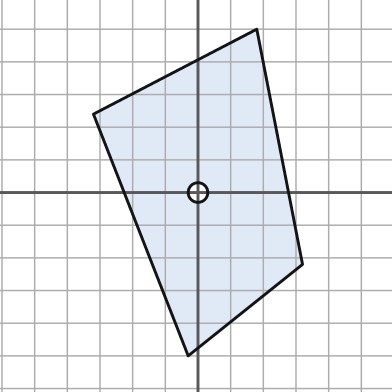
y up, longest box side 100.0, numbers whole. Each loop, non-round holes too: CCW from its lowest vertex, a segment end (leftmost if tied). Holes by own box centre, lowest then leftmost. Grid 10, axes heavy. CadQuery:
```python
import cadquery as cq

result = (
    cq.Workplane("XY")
    .moveTo(-3.0, -50.0)
    .lineTo(32.0, -22.0)
    .lineTo(18.0, 50.0)
    .lineTo(-32.0, 24.0)
    .close()
    .moveTo(0.0, 0.0)
    .circle(3.0)
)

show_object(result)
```